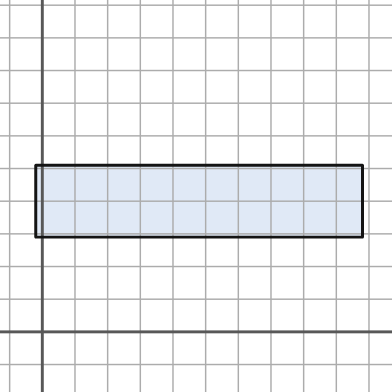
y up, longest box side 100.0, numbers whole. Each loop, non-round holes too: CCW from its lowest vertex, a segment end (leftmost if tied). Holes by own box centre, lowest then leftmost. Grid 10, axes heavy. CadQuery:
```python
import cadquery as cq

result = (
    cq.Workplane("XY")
    .moveTo(-2.0, 29.0)
    .lineTo(98.0, 29.0)
    .lineTo(98.0, 51.0)
    .lineTo(-2.0, 51.0)
    .close()
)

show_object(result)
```